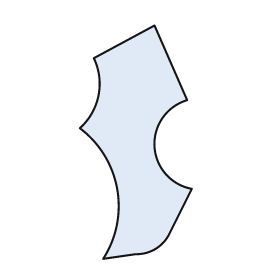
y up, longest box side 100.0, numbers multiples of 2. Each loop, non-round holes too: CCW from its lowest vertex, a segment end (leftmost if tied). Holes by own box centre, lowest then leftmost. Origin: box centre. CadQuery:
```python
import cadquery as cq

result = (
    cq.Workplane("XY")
    .moveTo(-14.0, -50.0)
    .lineTo(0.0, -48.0)
    .threePointArc((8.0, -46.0), (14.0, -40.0))
    .lineTo(24.0, -20.0)
    .threePointArc((8.0, -2.0), (22.0, 18.0))
    .lineTo(8.0, 50.0)
    .lineTo(-18.0, 36.0)
    .threePointArc((-16.0, 20.0), (-24.0, 6.0))
    .threePointArc((-8.0, -20.0), (-14.0, -50.0))
    .close()
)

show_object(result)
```